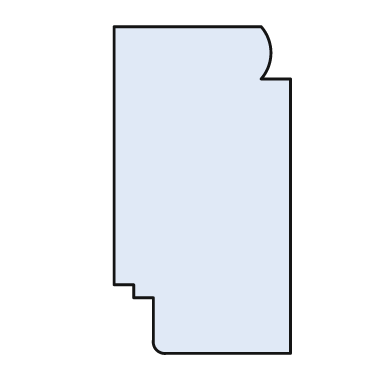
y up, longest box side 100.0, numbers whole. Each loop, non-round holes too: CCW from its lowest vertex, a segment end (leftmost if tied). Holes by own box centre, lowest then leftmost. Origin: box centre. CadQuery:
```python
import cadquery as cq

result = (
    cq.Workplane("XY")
    .moveTo(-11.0, -50.0)
    .lineTo(27.0, -50.0)
    .lineTo(27.0, 34.0)
    .lineTo(18.0, 34.0)
    .threePointArc((21.0, 42.0), (18.0, 50.0))
    .lineTo(-27.0, 50.0)
    .lineTo(-27.0, -29.0)
    .lineTo(-21.0, -29.0)
    .lineTo(-21.0, -33.0)
    .lineTo(-15.0, -33.0)
    .lineTo(-15.0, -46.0)
    .threePointArc((-14.0, -49.0), (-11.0, -50.0))
    .close()
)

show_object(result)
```